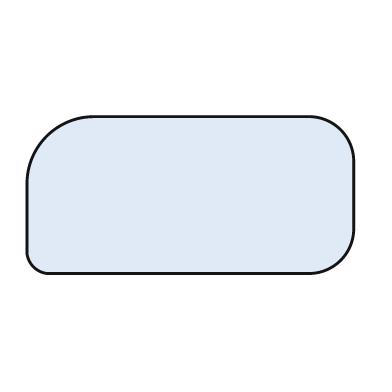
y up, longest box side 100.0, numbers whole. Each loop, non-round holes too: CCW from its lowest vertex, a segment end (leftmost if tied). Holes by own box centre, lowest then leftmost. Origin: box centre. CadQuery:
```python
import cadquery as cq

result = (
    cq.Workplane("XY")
    .moveTo(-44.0, -24.0)
    .lineTo(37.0, -24.0)
    .threePointArc((46.0, -20.0), (50.0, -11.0))
    .lineTo(50.0, 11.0)
    .threePointArc((46.0, 20.0), (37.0, 24.0))
    .lineTo(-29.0, 24.0)
    .threePointArc((-44.0, 18.0), (-50.0, 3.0))
    .lineTo(-50.0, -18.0)
    .threePointArc((-48.0, -22.0), (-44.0, -24.0))
    .close()
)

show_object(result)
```